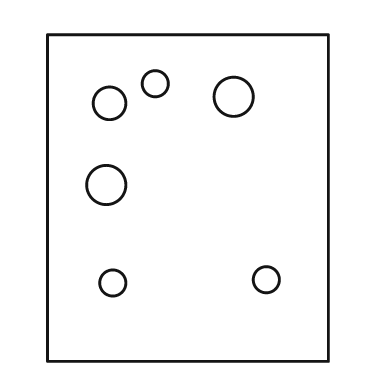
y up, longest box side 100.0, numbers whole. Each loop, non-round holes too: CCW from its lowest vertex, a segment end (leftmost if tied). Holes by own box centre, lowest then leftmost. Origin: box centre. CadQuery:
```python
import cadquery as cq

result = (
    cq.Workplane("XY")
    .moveTo(-43.0, -50.0)
    .lineTo(43.0, -50.0)
    .lineTo(43.0, 50.0)
    .lineTo(-43.0, 50.0)
    .close()
    .moveTo(-23.0, -26.0)
    .circle(4.0)
    .moveTo(24.0, -25.0)
    .circle(4.0)
    .moveTo(-25.0, 4.0)
    .circle(6.0)
    .moveTo(-24.0, 29.0)
    .circle(5.0)
    .moveTo(14.0, 31.0)
    .circle(6.0)
    .moveTo(-10.0, 35.0)
    .circle(4.0)
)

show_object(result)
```